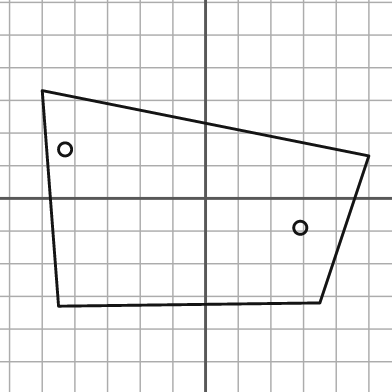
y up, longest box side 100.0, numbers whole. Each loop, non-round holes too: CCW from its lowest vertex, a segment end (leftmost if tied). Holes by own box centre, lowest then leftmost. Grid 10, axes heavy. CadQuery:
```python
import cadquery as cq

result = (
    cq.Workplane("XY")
    .moveTo(-45.0, -33.0)
    .lineTo(35.0, -32.0)
    .lineTo(50.0, 13.0)
    .lineTo(-50.0, 33.0)
    .close()
    .moveTo(29.0, -9.0)
    .circle(2.0)
    .moveTo(-43.0, 15.0)
    .circle(2.0)
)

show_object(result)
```